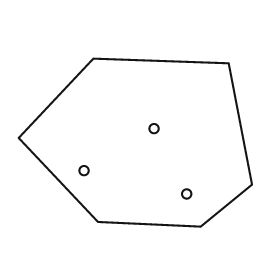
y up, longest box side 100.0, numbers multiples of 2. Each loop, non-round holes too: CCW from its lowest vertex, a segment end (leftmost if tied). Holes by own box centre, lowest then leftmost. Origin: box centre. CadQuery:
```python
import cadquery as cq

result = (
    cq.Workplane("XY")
    .moveTo(28.0, -36.0)
    .lineTo(50.0, -18.0)
    .lineTo(40.0, 34.0)
    .lineTo(-18.0, 36.0)
    .lineTo(-50.0, 2.0)
    .lineTo(-16.0, -34.0)
    .close()
    .moveTo(22.0, -22.0)
    .circle(2.0)
    .moveTo(-22.0, -12.0)
    .circle(2.0)
    .moveTo(8.0, 6.0)
    .circle(2.0)
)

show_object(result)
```